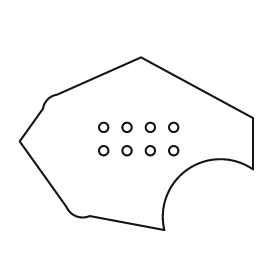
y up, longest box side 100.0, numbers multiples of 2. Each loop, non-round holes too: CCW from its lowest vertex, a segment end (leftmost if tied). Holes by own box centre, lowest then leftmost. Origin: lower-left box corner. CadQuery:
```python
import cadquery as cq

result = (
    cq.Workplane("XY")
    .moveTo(62.0, 0.0)
    .threePointArc((72.0, 26.0), (100.0, 26.0))
    .lineTo(100.0, 48.0)
    .lineTo(52.0, 74.0)
    .lineTo(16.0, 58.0)
    .threePointArc((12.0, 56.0), (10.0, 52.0))
    .lineTo(0.0, 38.0)
    .lineTo(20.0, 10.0)
    .threePointArc((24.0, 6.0), (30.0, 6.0))
    .close()
    .moveTo(36.0, 34.0)
    .circle(2.0)
    .moveTo(46.0, 34.0)
    .circle(2.0)
    .moveTo(56.0, 34.0)
    .circle(2.0)
    .moveTo(66.0, 34.0)
    .circle(2.0)
    .moveTo(36.0, 44.0)
    .circle(2.0)
    .moveTo(46.0, 44.0)
    .circle(2.0)
    .moveTo(56.0, 44.0)
    .circle(2.0)
    .moveTo(66.0, 44.0)
    .circle(2.0)
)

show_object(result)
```